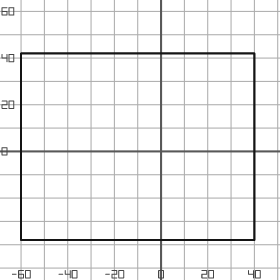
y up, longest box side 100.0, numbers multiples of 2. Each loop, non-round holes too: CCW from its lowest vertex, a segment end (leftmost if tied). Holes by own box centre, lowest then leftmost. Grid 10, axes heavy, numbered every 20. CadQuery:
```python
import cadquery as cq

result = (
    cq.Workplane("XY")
    .moveTo(-60.0, -38.0)
    .lineTo(40.0, -38.0)
    .lineTo(40.0, 42.0)
    .lineTo(-60.0, 42.0)
    .close()
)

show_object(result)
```